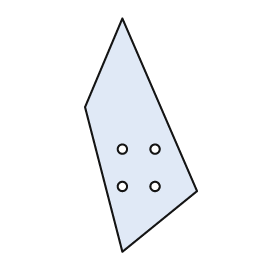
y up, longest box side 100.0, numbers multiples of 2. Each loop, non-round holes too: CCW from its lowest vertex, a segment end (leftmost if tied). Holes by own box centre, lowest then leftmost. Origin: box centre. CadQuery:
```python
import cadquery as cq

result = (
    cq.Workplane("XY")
    .moveTo(-8.0, -50.0)
    .lineTo(24.0, -24.0)
    .lineTo(-8.0, 50.0)
    .lineTo(-24.0, 12.0)
    .close()
    .moveTo(-8.0, -22.0)
    .circle(2.0)
    .moveTo(6.0, -22.0)
    .circle(2.0)
    .moveTo(-8.0, -6.0)
    .circle(2.0)
    .moveTo(6.0, -6.0)
    .circle(2.0)
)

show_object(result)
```